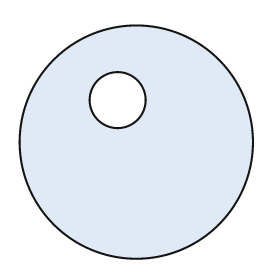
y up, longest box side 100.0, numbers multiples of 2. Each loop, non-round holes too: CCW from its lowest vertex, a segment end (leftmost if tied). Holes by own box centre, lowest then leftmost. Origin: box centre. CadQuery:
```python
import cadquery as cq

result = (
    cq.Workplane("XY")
    .moveTo(0.0, 0.0)
    .circle(50.0)
    .moveTo(-8.0, 18.0)
    .circle(12.0)
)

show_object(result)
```